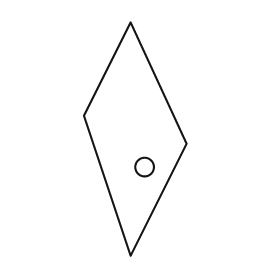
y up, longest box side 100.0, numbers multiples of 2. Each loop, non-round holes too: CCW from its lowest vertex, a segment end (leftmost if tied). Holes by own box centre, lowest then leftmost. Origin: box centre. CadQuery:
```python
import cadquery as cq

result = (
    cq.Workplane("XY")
    .moveTo(-2.0, -50.0)
    .lineTo(22.0, -2.0)
    .lineTo(-2.0, 50.0)
    .lineTo(-22.0, 10.0)
    .close()
    .moveTo(4.0, -12.0)
    .circle(4.0)
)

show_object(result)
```